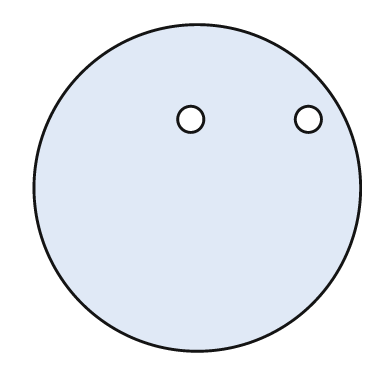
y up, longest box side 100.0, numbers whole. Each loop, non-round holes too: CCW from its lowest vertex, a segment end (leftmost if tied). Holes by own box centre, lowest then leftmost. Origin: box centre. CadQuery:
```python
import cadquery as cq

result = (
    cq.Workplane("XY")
    .moveTo(0.0, 0.0)
    .circle(50.0)
    .moveTo(-2.0, 21.0)
    .circle(4.0)
    .moveTo(34.0, 21.0)
    .circle(4.0)
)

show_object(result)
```